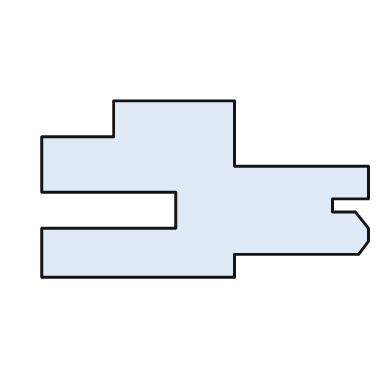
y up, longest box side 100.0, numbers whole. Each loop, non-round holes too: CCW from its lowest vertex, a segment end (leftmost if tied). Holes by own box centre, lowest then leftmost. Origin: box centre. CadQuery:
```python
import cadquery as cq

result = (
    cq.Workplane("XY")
    .moveTo(-50.0, -27.0)
    .lineTo(9.0, -27.0)
    .lineTo(9.0, -20.0)
    .lineTo(47.0, -20.0)
    .lineTo(50.0, -16.0)
    .lineTo(50.0, -12.0)
    .lineTo(46.0, -7.0)
    .lineTo(39.0, -7.0)
    .lineTo(39.0, -3.0)
    .lineTo(50.0, -3.0)
    .lineTo(50.0, 7.0)
    .lineTo(9.0, 7.0)
    .lineTo(9.0, 27.0)
    .lineTo(-28.0, 27.0)
    .lineTo(-28.0, 16.0)
    .lineTo(-50.0, 16.0)
    .lineTo(-50.0, -1.0)
    .lineTo(-9.0, -1.0)
    .lineTo(-9.0, -12.0)
    .lineTo(-50.0, -12.0)
    .close()
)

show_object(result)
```